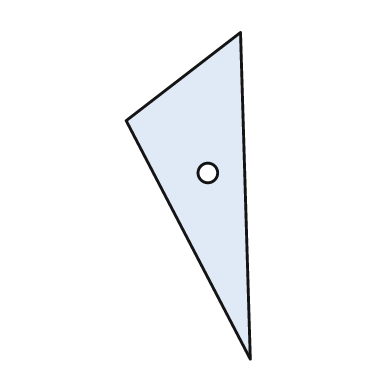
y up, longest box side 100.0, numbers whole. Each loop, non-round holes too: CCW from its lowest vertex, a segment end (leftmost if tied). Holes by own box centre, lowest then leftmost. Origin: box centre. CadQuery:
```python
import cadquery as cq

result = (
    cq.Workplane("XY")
    .moveTo(19.0, -50.0)
    .lineTo(16.0, 50.0)
    .lineTo(-19.0, 23.0)
    .close()
    .moveTo(6.0, 7.0)
    .circle(3.0)
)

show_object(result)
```